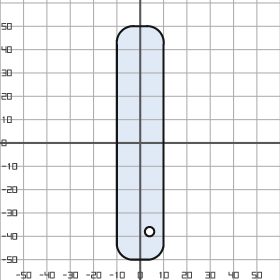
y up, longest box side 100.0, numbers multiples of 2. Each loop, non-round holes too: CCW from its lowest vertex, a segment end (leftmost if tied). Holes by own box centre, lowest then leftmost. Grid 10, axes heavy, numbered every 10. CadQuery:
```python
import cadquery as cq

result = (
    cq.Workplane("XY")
    .moveTo(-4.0, -50.0)
    .lineTo(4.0, -50.0)
    .threePointArc((8.0, -48.0), (10.0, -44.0))
    .lineTo(10.0, 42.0)
    .threePointArc((8.0, 48.0), (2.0, 50.0))
    .lineTo(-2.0, 50.0)
    .threePointArc((-8.0, 48.0), (-10.0, 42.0))
    .lineTo(-10.0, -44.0)
    .threePointArc((-8.0, -48.0), (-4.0, -50.0))
    .close()
    .moveTo(4.0, -38.0)
    .circle(2.0)
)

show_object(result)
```